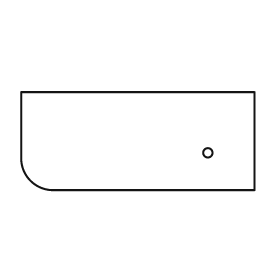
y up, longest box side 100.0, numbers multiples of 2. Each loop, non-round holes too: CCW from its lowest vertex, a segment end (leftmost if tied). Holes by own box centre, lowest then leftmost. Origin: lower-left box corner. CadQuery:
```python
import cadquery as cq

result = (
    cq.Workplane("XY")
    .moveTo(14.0, 0.0)
    .lineTo(100.0, 0.0)
    .lineTo(100.0, 42.0)
    .lineTo(0.0, 42.0)
    .lineTo(0.0, 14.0)
    .threePointArc((4.0, 4.0), (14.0, 0.0))
    .close()
    .moveTo(80.0, 16.0)
    .circle(2.0)
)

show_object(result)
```